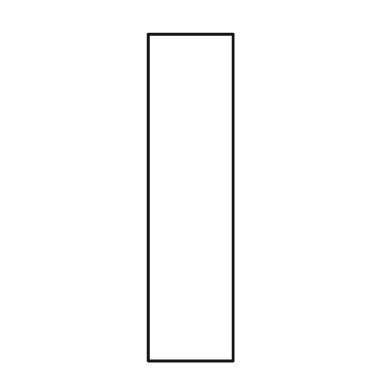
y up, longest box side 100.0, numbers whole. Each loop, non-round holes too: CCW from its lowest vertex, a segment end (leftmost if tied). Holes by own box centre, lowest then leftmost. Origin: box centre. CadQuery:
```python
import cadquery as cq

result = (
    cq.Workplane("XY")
    .moveTo(-13.0, -50.0)
    .lineTo(13.0, -50.0)
    .lineTo(13.0, 50.0)
    .lineTo(-13.0, 50.0)
    .close()
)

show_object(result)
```